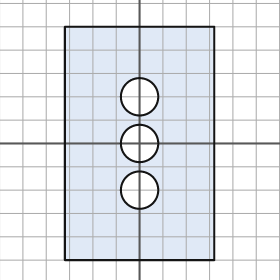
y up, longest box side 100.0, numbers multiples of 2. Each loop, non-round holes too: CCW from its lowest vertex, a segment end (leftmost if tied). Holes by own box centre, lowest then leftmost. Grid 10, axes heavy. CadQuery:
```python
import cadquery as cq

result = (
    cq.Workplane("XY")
    .moveTo(-32.0, -50.0)
    .lineTo(32.0, -50.0)
    .lineTo(32.0, 50.0)
    .lineTo(-32.0, 50.0)
    .close()
    .moveTo(0.0, -20.0)
    .circle(8.0)
    .moveTo(0.0, 0.0)
    .circle(8.0)
    .moveTo(0.0, 20.0)
    .circle(8.0)
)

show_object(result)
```